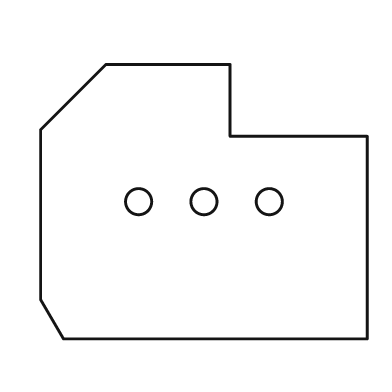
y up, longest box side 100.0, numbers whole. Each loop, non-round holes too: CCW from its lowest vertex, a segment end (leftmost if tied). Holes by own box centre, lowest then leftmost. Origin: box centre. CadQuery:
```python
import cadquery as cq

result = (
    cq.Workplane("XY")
    .moveTo(-43.0, -42.0)
    .lineTo(50.0, -42.0)
    .lineTo(50.0, 20.0)
    .lineTo(8.0, 20.0)
    .lineTo(8.0, 42.0)
    .lineTo(-30.0, 42.0)
    .lineTo(-50.0, 22.0)
    .lineTo(-50.0, -30.0)
    .close()
    .moveTo(-20.0, 0.0)
    .circle(4.0)
    .moveTo(0.0, 0.0)
    .circle(4.0)
    .moveTo(20.0, 0.0)
    .circle(4.0)
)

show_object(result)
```